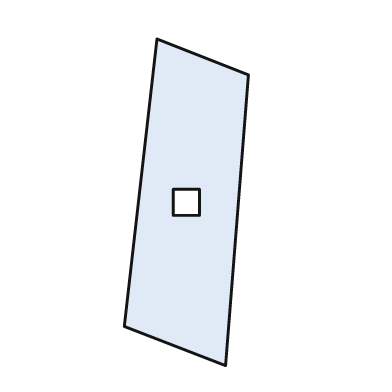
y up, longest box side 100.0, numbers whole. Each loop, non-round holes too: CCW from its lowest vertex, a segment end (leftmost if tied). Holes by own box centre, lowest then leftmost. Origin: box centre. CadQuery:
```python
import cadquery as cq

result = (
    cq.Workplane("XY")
    .moveTo(12.0, -50.0)
    .lineTo(19.0, 39.0)
    .lineTo(-9.0, 50.0)
    .lineTo(-19.0, -38.0)
    .close()
    .moveTo(-4.0, -4.0)
    .lineTo(4.0, -4.0)
    .lineTo(4.0, 4.0)
    .lineTo(-4.0, 4.0)
    .close()
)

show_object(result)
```